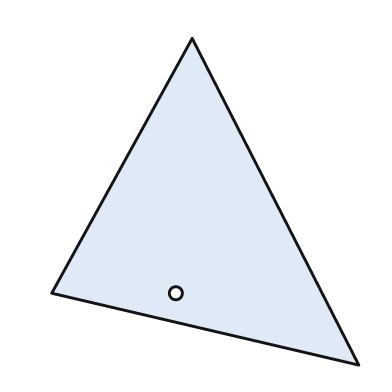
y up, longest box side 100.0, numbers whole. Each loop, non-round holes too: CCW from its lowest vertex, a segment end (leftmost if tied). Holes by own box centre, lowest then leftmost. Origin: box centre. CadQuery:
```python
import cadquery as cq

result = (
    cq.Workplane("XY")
    .moveTo(47.0, -50.0)
    .lineTo(-4.0, 50.0)
    .lineTo(-47.0, -28.0)
    .close()
    .moveTo(-9.0, -28.0)
    .circle(2.0)
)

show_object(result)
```